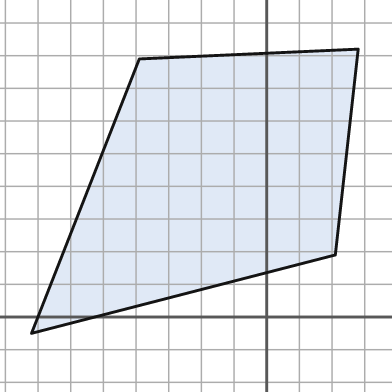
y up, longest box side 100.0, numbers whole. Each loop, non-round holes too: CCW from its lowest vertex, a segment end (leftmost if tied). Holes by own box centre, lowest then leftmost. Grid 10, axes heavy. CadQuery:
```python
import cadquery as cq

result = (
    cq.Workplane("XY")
    .moveTo(-72.0, -5.0)
    .lineTo(21.0, 19.0)
    .lineTo(28.0, 82.0)
    .lineTo(-39.0, 79.0)
    .close()
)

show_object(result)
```